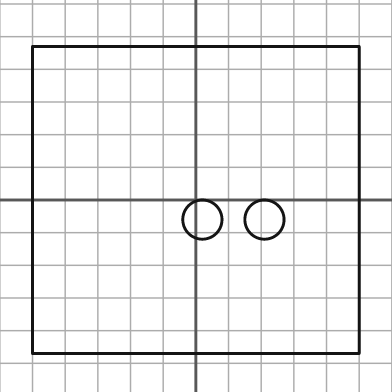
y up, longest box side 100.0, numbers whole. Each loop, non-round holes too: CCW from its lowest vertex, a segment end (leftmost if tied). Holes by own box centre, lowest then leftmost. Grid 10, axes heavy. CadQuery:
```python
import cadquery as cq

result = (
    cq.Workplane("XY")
    .moveTo(-50.0, -47.0)
    .lineTo(50.0, -47.0)
    .lineTo(50.0, 47.0)
    .lineTo(-50.0, 47.0)
    .close()
    .moveTo(2.0, -6.0)
    .circle(6.0)
    .moveTo(21.0, -6.0)
    .circle(6.0)
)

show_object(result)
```